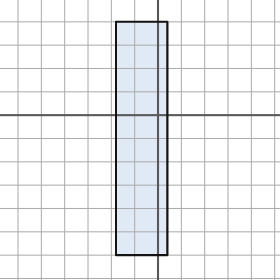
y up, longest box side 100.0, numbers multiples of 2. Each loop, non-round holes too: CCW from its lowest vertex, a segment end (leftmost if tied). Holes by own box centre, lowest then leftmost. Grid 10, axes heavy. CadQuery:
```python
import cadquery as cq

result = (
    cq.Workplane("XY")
    .moveTo(-18.0, -60.0)
    .lineTo(4.0, -60.0)
    .lineTo(4.0, 40.0)
    .lineTo(-18.0, 40.0)
    .close()
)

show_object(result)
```